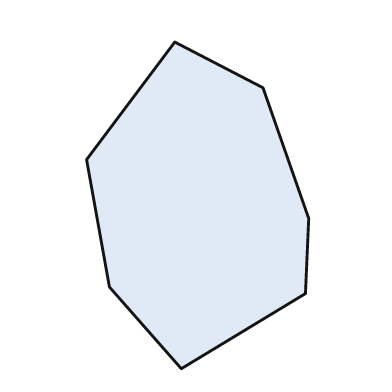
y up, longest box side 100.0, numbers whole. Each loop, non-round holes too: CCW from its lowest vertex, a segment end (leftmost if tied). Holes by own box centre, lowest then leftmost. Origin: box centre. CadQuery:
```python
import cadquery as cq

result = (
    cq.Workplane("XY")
    .moveTo(-5.0, -50.0)
    .lineTo(33.0, -27.0)
    .lineTo(34.0, -4.0)
    .lineTo(20.0, 36.0)
    .lineTo(-7.0, 50.0)
    .lineTo(-34.0, 14.0)
    .lineTo(-27.0, -25.0)
    .close()
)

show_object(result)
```